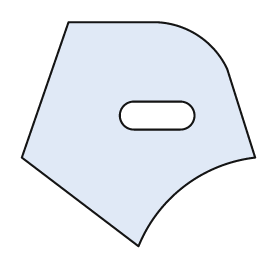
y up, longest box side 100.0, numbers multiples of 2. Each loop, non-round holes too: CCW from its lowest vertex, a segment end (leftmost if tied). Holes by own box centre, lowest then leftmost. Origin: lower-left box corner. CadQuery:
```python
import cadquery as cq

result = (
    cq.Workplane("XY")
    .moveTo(50.0, 0.0)
    .threePointArc((70.0, 26.0), (100.0, 38.0))
    .lineTo(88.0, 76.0)
    .threePointArc((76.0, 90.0), (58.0, 96.0))
    .lineTo(20.0, 96.0)
    .lineTo(0.0, 38.0)
    .close()
    .moveTo(48.0, 50.0)
    .lineTo(68.0, 50.0)
    .threePointArc((74.0, 56.0), (68.0, 62.0))
    .lineTo(48.0, 62.0)
    .threePointArc((42.0, 56.0), (48.0, 50.0))
    .close()
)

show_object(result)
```